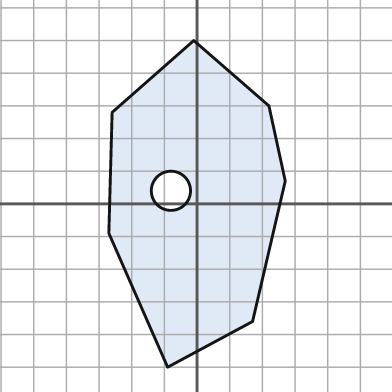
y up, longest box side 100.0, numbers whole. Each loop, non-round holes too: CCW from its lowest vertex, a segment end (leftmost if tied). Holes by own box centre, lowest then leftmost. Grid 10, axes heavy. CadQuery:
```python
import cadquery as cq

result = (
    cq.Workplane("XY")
    .moveTo(-9.0, -50.0)
    .lineTo(17.0, -36.0)
    .lineTo(27.0, 7.0)
    .lineTo(22.0, 30.0)
    .lineTo(-1.0, 50.0)
    .lineTo(-26.0, 28.0)
    .lineTo(-27.0, -9.0)
    .close()
    .moveTo(-8.0, 4.0)
    .circle(6.0)
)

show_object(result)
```